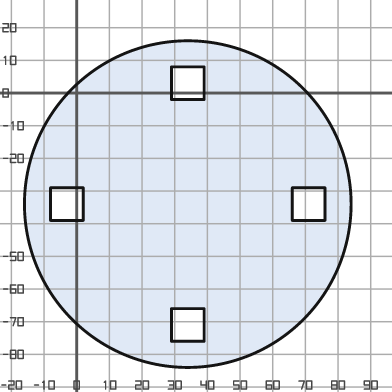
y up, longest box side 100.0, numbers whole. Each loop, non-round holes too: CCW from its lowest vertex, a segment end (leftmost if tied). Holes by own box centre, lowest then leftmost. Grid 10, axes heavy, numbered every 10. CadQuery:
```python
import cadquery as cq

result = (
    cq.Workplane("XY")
    .moveTo(34.0, -34.0)
    .circle(50.0)
    .moveTo(29.0, -76.0)
    .lineTo(39.0, -76.0)
    .lineTo(39.0, -66.0)
    .lineTo(29.0, -66.0)
    .close()
    .moveTo(-8.0, -39.0)
    .lineTo(2.0, -39.0)
    .lineTo(2.0, -29.0)
    .lineTo(-8.0, -29.0)
    .close()
    .moveTo(66.0, -39.0)
    .lineTo(76.0, -39.0)
    .lineTo(76.0, -29.0)
    .lineTo(66.0, -29.0)
    .close()
    .moveTo(29.0, -2.0)
    .lineTo(39.0, -2.0)
    .lineTo(39.0, 8.0)
    .lineTo(29.0, 8.0)
    .close()
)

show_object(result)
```